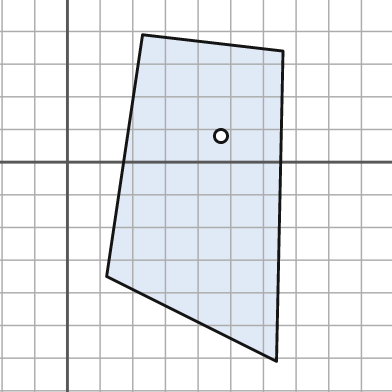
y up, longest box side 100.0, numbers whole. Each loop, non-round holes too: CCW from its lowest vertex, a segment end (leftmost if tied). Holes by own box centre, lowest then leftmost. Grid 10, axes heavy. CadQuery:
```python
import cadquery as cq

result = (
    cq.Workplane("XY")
    .moveTo(64.0, -61.0)
    .lineTo(66.0, 34.0)
    .lineTo(23.0, 39.0)
    .lineTo(12.0, -35.0)
    .close()
    .moveTo(47.0, 8.0)
    .circle(2.0)
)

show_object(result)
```